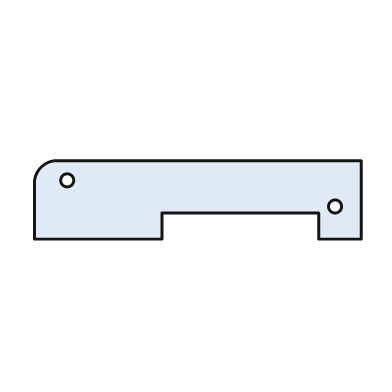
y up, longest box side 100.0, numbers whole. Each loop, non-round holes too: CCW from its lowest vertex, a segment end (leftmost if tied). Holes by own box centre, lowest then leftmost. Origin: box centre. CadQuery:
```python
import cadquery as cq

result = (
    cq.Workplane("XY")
    .moveTo(-50.0, -12.0)
    .lineTo(-11.0, -12.0)
    .lineTo(-11.0, -4.0)
    .lineTo(37.0, -4.0)
    .lineTo(37.0, -12.0)
    .lineTo(50.0, -12.0)
    .lineTo(50.0, 12.0)
    .lineTo(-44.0, 12.0)
    .threePointArc((-48.0, 10.0), (-50.0, 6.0))
    .close()
    .moveTo(42.0, -2.0)
    .circle(2.0)
    .moveTo(-40.0, 6.0)
    .circle(2.0)
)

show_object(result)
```